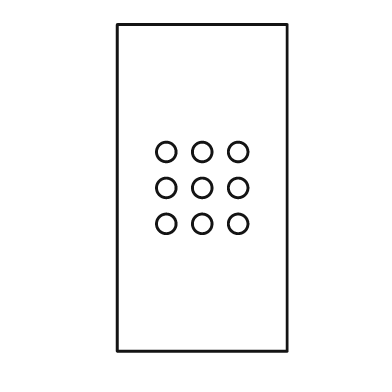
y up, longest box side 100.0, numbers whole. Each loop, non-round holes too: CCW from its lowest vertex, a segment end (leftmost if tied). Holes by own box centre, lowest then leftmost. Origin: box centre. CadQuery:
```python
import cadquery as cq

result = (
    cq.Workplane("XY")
    .moveTo(-26.0, -50.0)
    .lineTo(26.0, -50.0)
    .lineTo(26.0, 50.0)
    .lineTo(-26.0, 50.0)
    .close()
    .moveTo(-11.0, -11.0)
    .circle(3.0)
    .moveTo(0.0, -11.0)
    .circle(3.0)
    .moveTo(11.0, -11.0)
    .circle(3.0)
    .moveTo(-11.0, 0.0)
    .circle(3.0)
    .moveTo(0.0, 0.0)
    .circle(3.0)
    .moveTo(11.0, 0.0)
    .circle(3.0)
    .moveTo(-11.0, 11.0)
    .circle(3.0)
    .moveTo(0.0, 11.0)
    .circle(3.0)
    .moveTo(11.0, 11.0)
    .circle(3.0)
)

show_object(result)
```